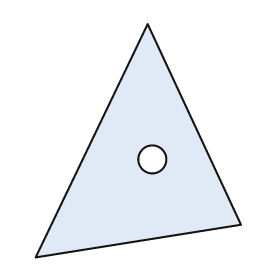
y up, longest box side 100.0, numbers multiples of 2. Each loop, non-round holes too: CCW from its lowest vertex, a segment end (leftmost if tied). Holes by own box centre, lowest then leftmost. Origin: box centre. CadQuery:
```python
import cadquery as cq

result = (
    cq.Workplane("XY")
    .moveTo(-44.0, -50.0)
    .lineTo(44.0, -36.0)
    .lineTo(4.0, 50.0)
    .close()
    .moveTo(6.0, -8.0)
    .circle(6.0)
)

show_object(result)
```